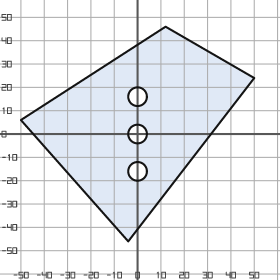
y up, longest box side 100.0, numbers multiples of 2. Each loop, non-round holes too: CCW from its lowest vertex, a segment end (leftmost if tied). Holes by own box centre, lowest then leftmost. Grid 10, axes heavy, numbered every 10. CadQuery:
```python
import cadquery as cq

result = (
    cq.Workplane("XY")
    .moveTo(-4.0, -46.0)
    .lineTo(50.0, 24.0)
    .lineTo(12.0, 46.0)
    .lineTo(-50.0, 6.0)
    .close()
    .moveTo(0.0, -16.0)
    .circle(4.0)
    .moveTo(0.0, 0.0)
    .circle(4.0)
    .moveTo(0.0, 16.0)
    .circle(4.0)
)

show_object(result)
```